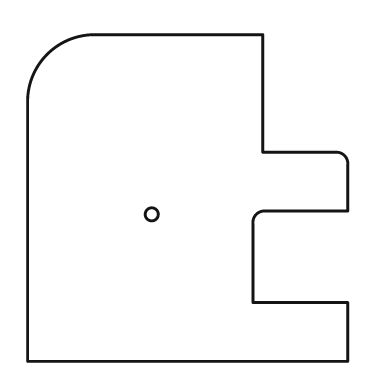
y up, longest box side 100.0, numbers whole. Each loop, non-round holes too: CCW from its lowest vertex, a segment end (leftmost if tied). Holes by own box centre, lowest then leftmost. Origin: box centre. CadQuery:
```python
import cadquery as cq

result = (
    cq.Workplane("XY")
    .moveTo(-49.0, -50.0)
    .lineTo(49.0, -50.0)
    .lineTo(49.0, -32.0)
    .lineTo(20.0, -32.0)
    .lineTo(20.0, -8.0)
    .threePointArc((21.0, -5.0), (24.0, -4.0))
    .lineTo(49.0, -4.0)
    .lineTo(49.0, 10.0)
    .threePointArc((48.0, 13.0), (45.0, 14.0))
    .lineTo(23.0, 14.0)
    .lineTo(23.0, 50.0)
    .lineTo(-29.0, 50.0)
    .threePointArc((-43.0, 44.0), (-49.0, 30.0))
    .close()
    .moveTo(-11.0, -5.0)
    .circle(2.0)
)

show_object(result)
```